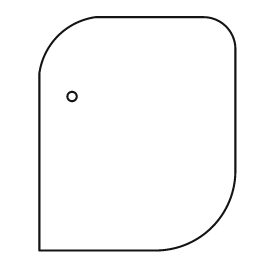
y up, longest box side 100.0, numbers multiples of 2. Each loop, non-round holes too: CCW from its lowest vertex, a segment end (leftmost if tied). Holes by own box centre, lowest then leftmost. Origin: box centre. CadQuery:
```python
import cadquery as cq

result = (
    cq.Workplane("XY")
    .moveTo(-42.0, -50.0)
    .lineTo(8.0, -50.0)
    .threePointArc((32.0, -40.0), (42.0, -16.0))
    .lineTo(42.0, 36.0)
    .threePointArc((38.0, 46.0), (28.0, 50.0))
    .lineTo(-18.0, 50.0)
    .threePointArc((-34.0, 42.0), (-42.0, 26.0))
    .close()
    .moveTo(-28.0, 16.0)
    .circle(2.0)
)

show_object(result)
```